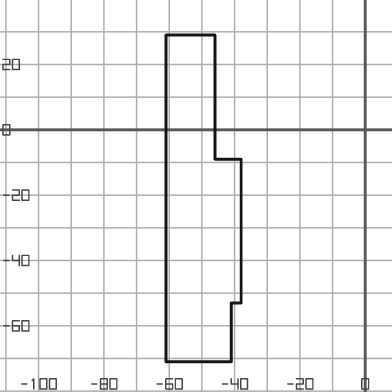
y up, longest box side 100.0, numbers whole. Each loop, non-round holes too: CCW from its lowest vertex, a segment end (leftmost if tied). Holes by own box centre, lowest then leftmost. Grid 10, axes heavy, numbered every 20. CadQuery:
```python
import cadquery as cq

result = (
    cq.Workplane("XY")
    .moveTo(-61.0, -71.0)
    .lineTo(-41.0, -71.0)
    .lineTo(-41.0, -53.0)
    .lineTo(-38.0, -53.0)
    .lineTo(-38.0, -9.0)
    .lineTo(-46.0, -9.0)
    .lineTo(-46.0, 29.0)
    .lineTo(-61.0, 29.0)
    .close()
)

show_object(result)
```